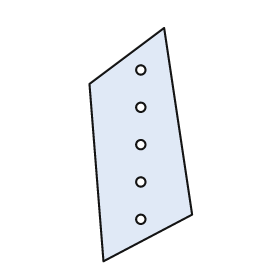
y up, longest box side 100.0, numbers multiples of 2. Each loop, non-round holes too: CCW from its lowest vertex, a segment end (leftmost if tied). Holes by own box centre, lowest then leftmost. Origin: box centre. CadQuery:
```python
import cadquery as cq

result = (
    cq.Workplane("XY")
    .moveTo(-16.0, -50.0)
    .lineTo(22.0, -30.0)
    .lineTo(10.0, 50.0)
    .lineTo(-22.0, 26.0)
    .close()
    .moveTo(0.0, -32.0)
    .circle(2.0)
    .moveTo(0.0, -16.0)
    .circle(2.0)
    .moveTo(0.0, 0.0)
    .circle(2.0)
    .moveTo(0.0, 16.0)
    .circle(2.0)
    .moveTo(0.0, 32.0)
    .circle(2.0)
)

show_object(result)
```